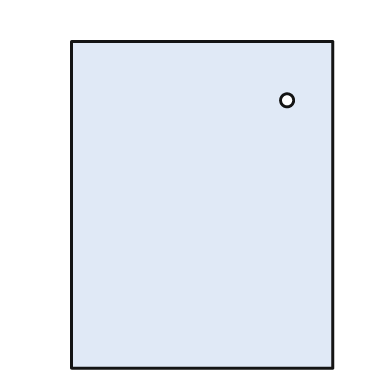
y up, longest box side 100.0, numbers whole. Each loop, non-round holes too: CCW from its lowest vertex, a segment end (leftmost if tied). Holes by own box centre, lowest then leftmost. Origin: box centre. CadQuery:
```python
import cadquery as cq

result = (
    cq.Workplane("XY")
    .moveTo(-40.0, -50.0)
    .lineTo(40.0, -50.0)
    .lineTo(40.0, 50.0)
    .lineTo(-40.0, 50.0)
    .close()
    .moveTo(26.0, 32.0)
    .circle(2.0)
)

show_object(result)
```